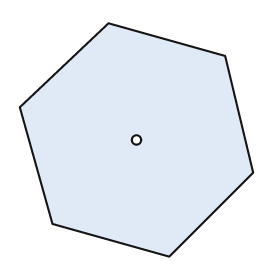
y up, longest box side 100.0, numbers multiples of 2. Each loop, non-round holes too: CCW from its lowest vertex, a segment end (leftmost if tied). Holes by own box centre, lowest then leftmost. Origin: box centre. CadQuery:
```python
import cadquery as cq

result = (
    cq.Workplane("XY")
    .moveTo(14.0, -50.0)
    .lineTo(50.0, -14.0)
    .lineTo(38.0, 36.0)
    .lineTo(-12.0, 50.0)
    .lineTo(-50.0, 14.0)
    .lineTo(-36.0, -36.0)
    .close()
    .moveTo(0.0, 0.0)
    .circle(2.0)
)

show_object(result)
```